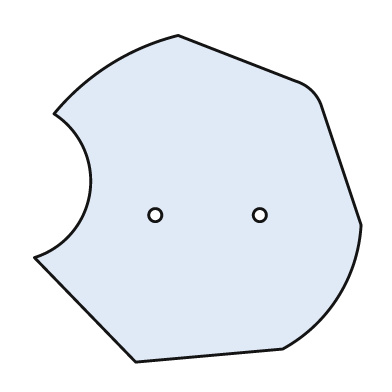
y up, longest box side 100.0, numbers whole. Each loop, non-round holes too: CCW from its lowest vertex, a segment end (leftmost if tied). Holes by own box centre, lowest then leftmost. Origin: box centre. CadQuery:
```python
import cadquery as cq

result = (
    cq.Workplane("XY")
    .moveTo(-19.0, -50.0)
    .lineTo(26.0, -46.0)
    .threePointArc((43.0, -30.0), (50.0, -8.0))
    .lineTo(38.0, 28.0)
    .threePointArc((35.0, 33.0), (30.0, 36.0))
    .lineTo(-6.0, 50.0)
    .threePointArc((-27.0, 41.0), (-44.0, 26.0))
    .threePointArc((-33.0, 2.0), (-50.0, -18.0))
    .close()
    .moveTo(-13.0, -5.0)
    .circle(2.0)
    .moveTo(19.0, -5.0)
    .circle(2.0)
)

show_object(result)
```